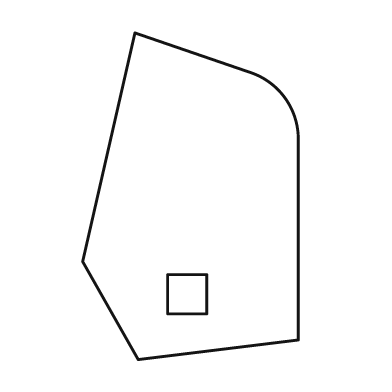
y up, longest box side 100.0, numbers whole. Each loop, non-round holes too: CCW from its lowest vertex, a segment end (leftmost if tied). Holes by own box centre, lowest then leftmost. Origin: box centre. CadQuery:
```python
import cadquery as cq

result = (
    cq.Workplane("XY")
    .moveTo(-16.0, -50.0)
    .lineTo(33.0, -44.0)
    .lineTo(33.0, 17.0)
    .threePointArc((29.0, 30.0), (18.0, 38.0))
    .lineTo(-17.0, 50.0)
    .lineTo(-33.0, -20.0)
    .close()
    .moveTo(-7.0, -36.0)
    .lineTo(5.0, -36.0)
    .lineTo(5.0, -24.0)
    .lineTo(-7.0, -24.0)
    .close()
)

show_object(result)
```